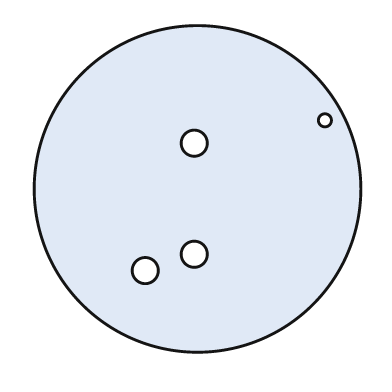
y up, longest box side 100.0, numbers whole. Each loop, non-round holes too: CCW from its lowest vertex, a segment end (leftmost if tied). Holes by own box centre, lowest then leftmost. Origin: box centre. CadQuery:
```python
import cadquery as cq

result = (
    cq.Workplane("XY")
    .moveTo(0.0, 0.0)
    .circle(50.0)
    .moveTo(-16.0, -25.0)
    .circle(4.0)
    .moveTo(-1.0, -20.0)
    .circle(4.0)
    .moveTo(-1.0, 14.0)
    .circle(4.0)
    .moveTo(39.0, 21.0)
    .circle(2.0)
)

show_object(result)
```